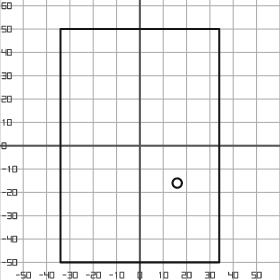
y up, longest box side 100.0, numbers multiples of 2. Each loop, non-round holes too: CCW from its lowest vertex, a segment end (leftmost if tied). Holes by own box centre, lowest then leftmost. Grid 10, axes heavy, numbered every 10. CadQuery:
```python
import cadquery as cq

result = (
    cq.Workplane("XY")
    .moveTo(-34.0, -50.0)
    .lineTo(34.0, -50.0)
    .lineTo(34.0, 50.0)
    .lineTo(-34.0, 50.0)
    .close()
    .moveTo(16.0, -16.0)
    .circle(2.0)
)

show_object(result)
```